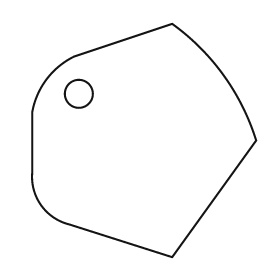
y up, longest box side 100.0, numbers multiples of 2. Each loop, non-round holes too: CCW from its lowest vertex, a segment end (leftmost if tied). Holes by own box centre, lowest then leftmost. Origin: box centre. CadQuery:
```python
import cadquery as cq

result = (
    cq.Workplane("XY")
    .moveTo(12.0, -50.0)
    .lineTo(48.0, 0.0)
    .threePointArc((34.0, 28.0), (12.0, 50.0))
    .lineTo(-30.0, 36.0)
    .threePointArc((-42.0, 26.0), (-48.0, 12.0))
    .lineTo(-48.0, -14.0)
    .threePointArc((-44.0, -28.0), (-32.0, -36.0))
    .close()
    .moveTo(-28.0, 20.0)
    .circle(6.0)
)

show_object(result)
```